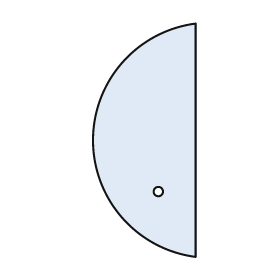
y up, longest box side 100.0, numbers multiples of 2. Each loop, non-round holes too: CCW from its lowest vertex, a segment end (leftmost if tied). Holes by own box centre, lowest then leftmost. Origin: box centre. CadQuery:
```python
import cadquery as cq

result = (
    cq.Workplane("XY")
    .moveTo(22.0, -50.0)
    .lineTo(22.0, 50.0)
    .threePointArc((-22.0, 0.0), (22.0, -50.0))
    .close()
    .moveTo(6.0, -22.0)
    .circle(2.0)
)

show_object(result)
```